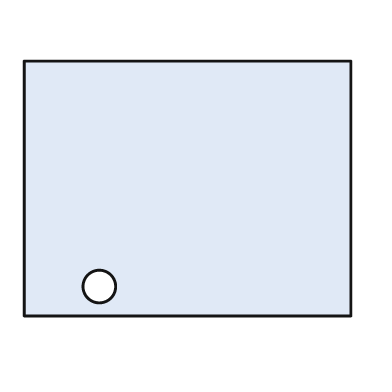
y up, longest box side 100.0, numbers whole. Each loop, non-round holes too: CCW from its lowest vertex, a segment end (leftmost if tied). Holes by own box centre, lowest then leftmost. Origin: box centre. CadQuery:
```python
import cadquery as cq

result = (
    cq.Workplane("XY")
    .moveTo(-50.0, -39.0)
    .lineTo(50.0, -39.0)
    .lineTo(50.0, 39.0)
    .lineTo(-50.0, 39.0)
    .close()
    .moveTo(-27.0, -30.0)
    .circle(5.0)
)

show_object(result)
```